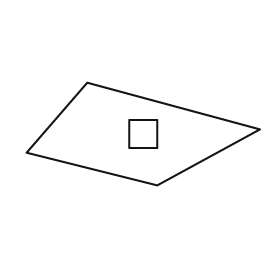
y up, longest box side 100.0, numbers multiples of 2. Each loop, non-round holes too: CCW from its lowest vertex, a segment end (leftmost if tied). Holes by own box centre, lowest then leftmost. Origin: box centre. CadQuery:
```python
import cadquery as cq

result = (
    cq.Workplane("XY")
    .moveTo(6.0, -22.0)
    .lineTo(50.0, 2.0)
    .lineTo(-24.0, 22.0)
    .lineTo(-50.0, -8.0)
    .close()
    .moveTo(-6.0, -6.0)
    .lineTo(6.0, -6.0)
    .lineTo(6.0, 6.0)
    .lineTo(-6.0, 6.0)
    .close()
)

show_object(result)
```